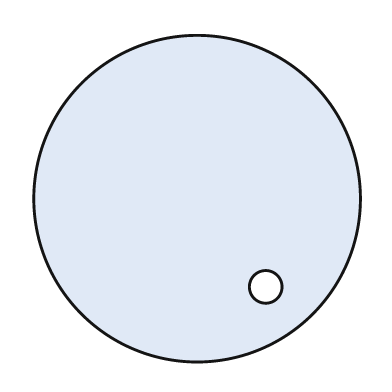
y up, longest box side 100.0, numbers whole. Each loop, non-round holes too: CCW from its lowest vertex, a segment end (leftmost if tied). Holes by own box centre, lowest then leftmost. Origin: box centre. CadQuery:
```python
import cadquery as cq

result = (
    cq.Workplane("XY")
    .moveTo(0.0, 0.0)
    .circle(50.0)
    .moveTo(21.0, -27.0)
    .circle(5.0)
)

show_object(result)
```